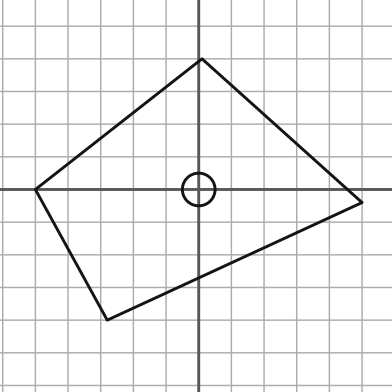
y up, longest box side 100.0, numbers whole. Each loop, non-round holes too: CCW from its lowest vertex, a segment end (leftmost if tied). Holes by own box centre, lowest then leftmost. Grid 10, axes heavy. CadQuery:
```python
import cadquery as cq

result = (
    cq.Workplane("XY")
    .moveTo(-28.0, -40.0)
    .lineTo(50.0, -4.0)
    .lineTo(1.0, 40.0)
    .lineTo(-50.0, 0.0)
    .close()
    .moveTo(0.0, 0.0)
    .circle(5.0)
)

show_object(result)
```